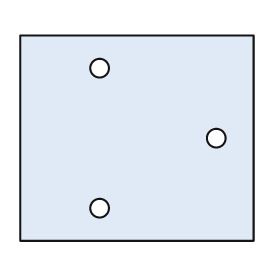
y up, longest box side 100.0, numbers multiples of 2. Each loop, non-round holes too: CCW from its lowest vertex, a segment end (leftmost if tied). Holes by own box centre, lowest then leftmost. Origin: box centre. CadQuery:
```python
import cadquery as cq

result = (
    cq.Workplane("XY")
    .moveTo(-50.0, -44.0)
    .lineTo(50.0, -44.0)
    .lineTo(50.0, 44.0)
    .lineTo(-50.0, 44.0)
    .close()
    .moveTo(-16.0, -30.0)
    .circle(4.0)
    .moveTo(34.0, 0.0)
    .circle(4.0)
    .moveTo(-16.0, 30.0)
    .circle(4.0)
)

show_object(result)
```